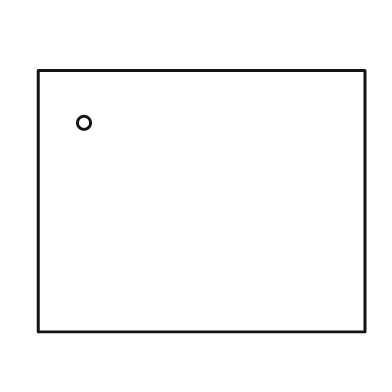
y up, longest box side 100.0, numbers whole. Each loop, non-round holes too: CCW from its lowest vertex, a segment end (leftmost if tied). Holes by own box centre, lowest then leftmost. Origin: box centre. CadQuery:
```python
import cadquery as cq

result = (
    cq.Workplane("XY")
    .moveTo(-50.0, -40.0)
    .lineTo(50.0, -40.0)
    .lineTo(50.0, 40.0)
    .lineTo(-50.0, 40.0)
    .close()
    .moveTo(-36.0, 24.0)
    .circle(2.0)
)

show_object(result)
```